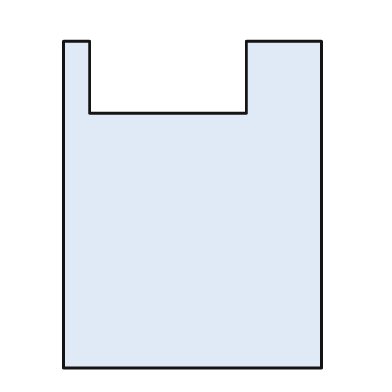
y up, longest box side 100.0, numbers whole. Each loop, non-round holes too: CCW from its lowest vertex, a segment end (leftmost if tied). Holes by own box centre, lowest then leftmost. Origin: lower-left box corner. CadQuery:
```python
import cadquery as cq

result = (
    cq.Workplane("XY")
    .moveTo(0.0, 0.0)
    .lineTo(79.0, 0.0)
    .lineTo(79.0, 100.0)
    .lineTo(56.0, 100.0)
    .lineTo(56.0, 78.0)
    .lineTo(8.0, 78.0)
    .lineTo(8.0, 100.0)
    .lineTo(0.0, 100.0)
    .close()
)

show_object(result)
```